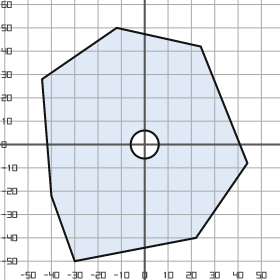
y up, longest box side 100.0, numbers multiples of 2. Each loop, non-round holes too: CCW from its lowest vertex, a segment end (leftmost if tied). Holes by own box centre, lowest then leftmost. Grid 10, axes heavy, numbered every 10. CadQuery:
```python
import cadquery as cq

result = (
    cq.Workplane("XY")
    .moveTo(-30.0, -50.0)
    .lineTo(22.0, -40.0)
    .lineTo(44.0, -8.0)
    .lineTo(24.0, 42.0)
    .lineTo(-12.0, 50.0)
    .lineTo(-44.0, 28.0)
    .lineTo(-40.0, -22.0)
    .close()
    .moveTo(0.0, 0.0)
    .circle(6.0)
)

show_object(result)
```